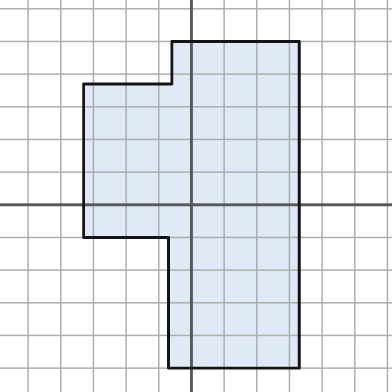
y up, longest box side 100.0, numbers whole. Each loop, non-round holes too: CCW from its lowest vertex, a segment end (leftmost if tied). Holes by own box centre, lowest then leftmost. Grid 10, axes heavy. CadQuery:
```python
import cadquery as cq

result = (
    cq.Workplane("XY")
    .moveTo(-7.0, -50.0)
    .lineTo(33.0, -50.0)
    .lineTo(33.0, 50.0)
    .lineTo(-6.0, 50.0)
    .lineTo(-6.0, 37.0)
    .lineTo(-33.0, 37.0)
    .lineTo(-33.0, -10.0)
    .lineTo(-7.0, -10.0)
    .close()
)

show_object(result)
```